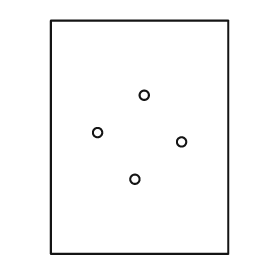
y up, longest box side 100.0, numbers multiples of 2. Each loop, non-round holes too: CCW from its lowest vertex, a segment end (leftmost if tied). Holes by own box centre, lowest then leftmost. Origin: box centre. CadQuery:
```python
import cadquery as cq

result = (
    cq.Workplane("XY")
    .moveTo(-38.0, -50.0)
    .lineTo(38.0, -50.0)
    .lineTo(38.0, 50.0)
    .lineTo(-38.0, 50.0)
    .close()
    .moveTo(-2.0, -18.0)
    .circle(2.0)
    .moveTo(18.0, -2.0)
    .circle(2.0)
    .moveTo(-18.0, 2.0)
    .circle(2.0)
    .moveTo(2.0, 18.0)
    .circle(2.0)
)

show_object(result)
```